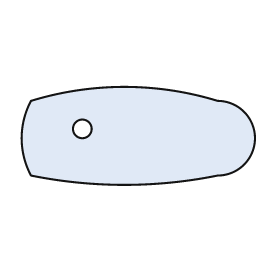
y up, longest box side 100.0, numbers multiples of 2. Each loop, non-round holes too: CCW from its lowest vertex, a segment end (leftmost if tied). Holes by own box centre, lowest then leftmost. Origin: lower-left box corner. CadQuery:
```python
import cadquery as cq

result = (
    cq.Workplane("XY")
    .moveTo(4.0, 4.0)
    .threePointArc((44.0, 0.0), (84.0, 4.0))
    .threePointArc((100.0, 20.0), (84.0, 36.0))
    .threePointArc((44.0, 42.0), (4.0, 36.0))
    .threePointArc((0.0, 20.0), (4.0, 4.0))
    .close()
    .moveTo(26.0, 24.0)
    .circle(4.0)
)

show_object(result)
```